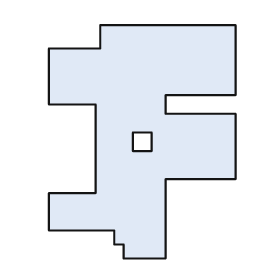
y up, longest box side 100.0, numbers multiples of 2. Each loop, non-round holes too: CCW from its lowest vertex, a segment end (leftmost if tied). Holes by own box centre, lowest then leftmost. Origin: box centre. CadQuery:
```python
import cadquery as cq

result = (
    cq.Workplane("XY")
    .moveTo(-8.0, -50.0)
    .lineTo(10.0, -50.0)
    .lineTo(10.0, -16.0)
    .lineTo(40.0, -16.0)
    .lineTo(40.0, 12.0)
    .lineTo(10.0, 12.0)
    .lineTo(10.0, 20.0)
    .lineTo(40.0, 20.0)
    .lineTo(40.0, 50.0)
    .lineTo(-18.0, 50.0)
    .lineTo(-18.0, 40.0)
    .lineTo(-40.0, 40.0)
    .lineTo(-40.0, 16.0)
    .lineTo(-20.0, 16.0)
    .lineTo(-20.0, -22.0)
    .lineTo(-40.0, -22.0)
    .lineTo(-40.0, -38.0)
    .lineTo(-12.0, -38.0)
    .lineTo(-12.0, -44.0)
    .lineTo(-8.0, -44.0)
    .close()
    .moveTo(-4.0, -4.0)
    .lineTo(4.0, -4.0)
    .lineTo(4.0, 4.0)
    .lineTo(-4.0, 4.0)
    .close()
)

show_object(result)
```